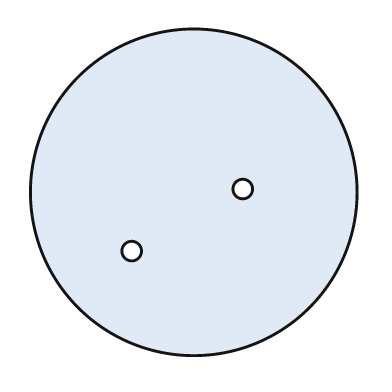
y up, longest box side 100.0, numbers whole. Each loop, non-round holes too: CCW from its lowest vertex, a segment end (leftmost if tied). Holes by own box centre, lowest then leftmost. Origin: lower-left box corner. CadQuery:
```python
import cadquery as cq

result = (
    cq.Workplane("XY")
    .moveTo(50.0, 50.0)
    .circle(50.0)
    .moveTo(31.0, 32.0)
    .circle(3.0)
    .moveTo(65.0, 51.0)
    .circle(3.0)
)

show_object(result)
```